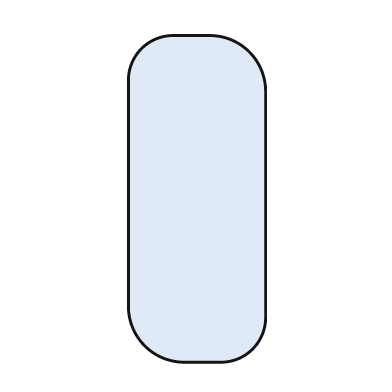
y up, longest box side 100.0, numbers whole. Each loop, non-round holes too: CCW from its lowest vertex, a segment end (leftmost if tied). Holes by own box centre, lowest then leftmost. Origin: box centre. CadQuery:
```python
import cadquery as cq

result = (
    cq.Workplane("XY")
    .moveTo(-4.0, -50.0)
    .lineTo(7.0, -50.0)
    .threePointArc((17.0, -46.0), (21.0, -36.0))
    .lineTo(21.0, 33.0)
    .threePointArc((16.0, 45.0), (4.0, 50.0))
    .lineTo(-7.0, 50.0)
    .threePointArc((-17.0, 46.0), (-21.0, 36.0))
    .lineTo(-21.0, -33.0)
    .threePointArc((-16.0, -45.0), (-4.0, -50.0))
    .close()
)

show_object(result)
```